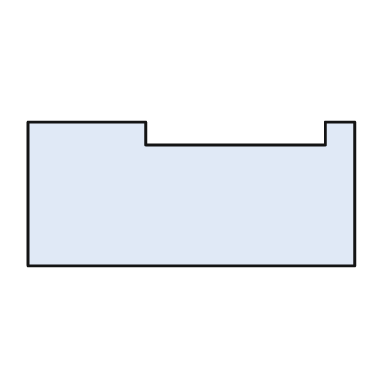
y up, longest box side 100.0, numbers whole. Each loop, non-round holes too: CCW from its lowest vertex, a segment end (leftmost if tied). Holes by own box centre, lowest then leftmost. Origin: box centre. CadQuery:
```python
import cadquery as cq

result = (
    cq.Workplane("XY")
    .moveTo(-50.0, -22.0)
    .lineTo(50.0, -22.0)
    .lineTo(50.0, 22.0)
    .lineTo(41.0, 22.0)
    .lineTo(41.0, 15.0)
    .lineTo(-14.0, 15.0)
    .lineTo(-14.0, 22.0)
    .lineTo(-50.0, 22.0)
    .close()
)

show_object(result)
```